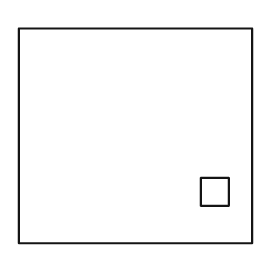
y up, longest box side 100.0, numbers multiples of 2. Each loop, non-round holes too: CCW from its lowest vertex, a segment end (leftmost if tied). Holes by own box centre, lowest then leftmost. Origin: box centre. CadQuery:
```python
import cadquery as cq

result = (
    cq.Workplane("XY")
    .moveTo(-50.0, -46.0)
    .lineTo(50.0, -46.0)
    .lineTo(50.0, 46.0)
    .lineTo(-50.0, 46.0)
    .close()
    .moveTo(28.0, -30.0)
    .lineTo(40.0, -30.0)
    .lineTo(40.0, -18.0)
    .lineTo(28.0, -18.0)
    .close()
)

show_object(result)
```